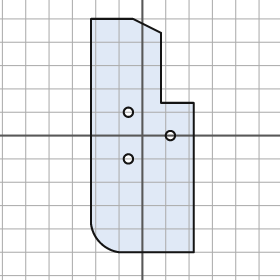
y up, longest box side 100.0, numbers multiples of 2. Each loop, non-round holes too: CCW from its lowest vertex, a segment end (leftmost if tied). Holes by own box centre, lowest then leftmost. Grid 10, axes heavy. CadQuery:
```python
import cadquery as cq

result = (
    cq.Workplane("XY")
    .moveTo(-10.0, -50.0)
    .lineTo(22.0, -50.0)
    .lineTo(22.0, 14.0)
    .lineTo(8.0, 14.0)
    .lineTo(8.0, 44.0)
    .lineTo(-4.0, 50.0)
    .lineTo(-22.0, 50.0)
    .lineTo(-22.0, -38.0)
    .threePointArc((-18.0, -46.0), (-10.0, -50.0))
    .close()
    .moveTo(-6.0, -10.0)
    .circle(2.0)
    .moveTo(12.0, 0.0)
    .circle(2.0)
    .moveTo(-6.0, 10.0)
    .circle(2.0)
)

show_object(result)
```